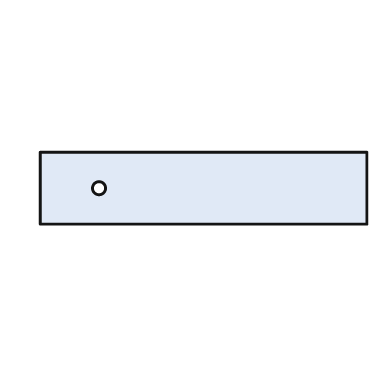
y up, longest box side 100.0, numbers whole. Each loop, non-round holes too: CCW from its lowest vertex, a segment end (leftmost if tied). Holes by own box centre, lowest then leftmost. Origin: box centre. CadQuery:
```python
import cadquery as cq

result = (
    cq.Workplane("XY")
    .moveTo(-50.0, -11.0)
    .lineTo(50.0, -11.0)
    .lineTo(50.0, 11.0)
    .lineTo(-50.0, 11.0)
    .close()
    .moveTo(-32.0, 0.0)
    .circle(2.0)
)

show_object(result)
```